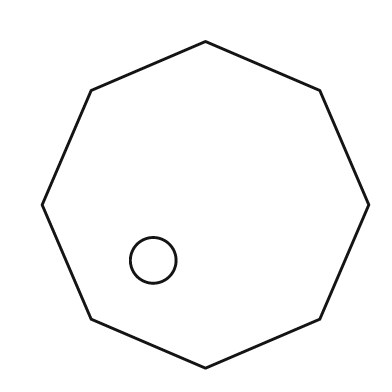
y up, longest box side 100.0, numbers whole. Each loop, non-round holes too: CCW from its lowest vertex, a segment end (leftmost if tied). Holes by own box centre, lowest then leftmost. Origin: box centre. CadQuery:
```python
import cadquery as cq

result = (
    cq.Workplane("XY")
    .moveTo(0.0, -50.0)
    .lineTo(35.0, -35.0)
    .lineTo(50.0, 0.0)
    .lineTo(35.0, 35.0)
    .lineTo(0.0, 50.0)
    .lineTo(-35.0, 35.0)
    .lineTo(-50.0, 0.0)
    .lineTo(-35.0, -35.0)
    .close()
    .moveTo(-16.0, -17.0)
    .circle(7.0)
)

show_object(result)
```